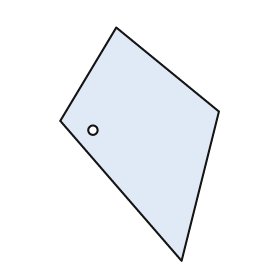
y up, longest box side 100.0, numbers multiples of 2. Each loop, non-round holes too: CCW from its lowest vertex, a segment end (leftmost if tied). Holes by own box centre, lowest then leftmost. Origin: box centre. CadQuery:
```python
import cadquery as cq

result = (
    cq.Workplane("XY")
    .moveTo(18.0, -50.0)
    .lineTo(34.0, 14.0)
    .lineTo(-10.0, 50.0)
    .lineTo(-34.0, 10.0)
    .close()
    .moveTo(-20.0, 6.0)
    .circle(2.0)
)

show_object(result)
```